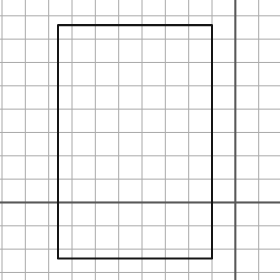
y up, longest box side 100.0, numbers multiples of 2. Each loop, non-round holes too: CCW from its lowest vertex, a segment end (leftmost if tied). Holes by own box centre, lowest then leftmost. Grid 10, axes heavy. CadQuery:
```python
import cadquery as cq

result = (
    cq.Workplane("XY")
    .moveTo(-76.0, -24.0)
    .lineTo(-10.0, -24.0)
    .lineTo(-10.0, 76.0)
    .lineTo(-76.0, 76.0)
    .close()
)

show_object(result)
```